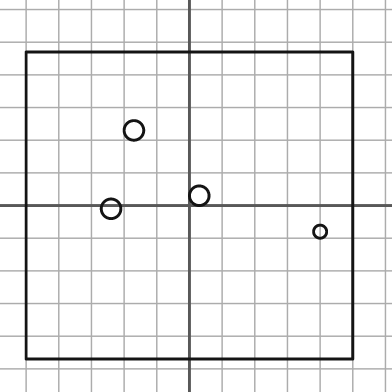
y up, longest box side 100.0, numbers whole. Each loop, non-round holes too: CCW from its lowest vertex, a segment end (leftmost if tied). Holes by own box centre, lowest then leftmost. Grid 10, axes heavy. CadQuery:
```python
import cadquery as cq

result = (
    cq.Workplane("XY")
    .moveTo(-50.0, -47.0)
    .lineTo(50.0, -47.0)
    .lineTo(50.0, 47.0)
    .lineTo(-50.0, 47.0)
    .close()
    .moveTo(40.0, -8.0)
    .circle(2.0)
    .moveTo(-24.0, -1.0)
    .circle(3.0)
    .moveTo(3.0, 3.0)
    .circle(3.0)
    .moveTo(-17.0, 23.0)
    .circle(3.0)
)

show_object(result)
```